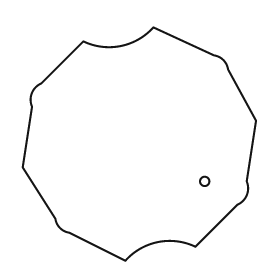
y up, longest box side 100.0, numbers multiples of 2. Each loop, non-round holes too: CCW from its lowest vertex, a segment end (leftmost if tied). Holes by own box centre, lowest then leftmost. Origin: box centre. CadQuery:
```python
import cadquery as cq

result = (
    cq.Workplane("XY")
    .moveTo(-6.0, -50.0)
    .threePointArc((8.0, -42.0), (24.0, -44.0))
    .lineTo(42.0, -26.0)
    .threePointArc((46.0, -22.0), (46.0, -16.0))
    .lineTo(50.0, 10.0)
    .lineTo(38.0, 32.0)
    .threePointArc((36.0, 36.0), (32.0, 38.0))
    .lineTo(6.0, 50.0)
    .threePointArc((-8.0, 42.0), (-24.0, 44.0))
    .lineTo(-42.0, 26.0)
    .threePointArc((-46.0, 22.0), (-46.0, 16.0))
    .lineTo(-50.0, -10.0)
    .lineTo(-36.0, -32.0)
    .threePointArc((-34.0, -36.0), (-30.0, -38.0))
    .close()
    .moveTo(28.0, -16.0)
    .circle(2.0)
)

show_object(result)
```